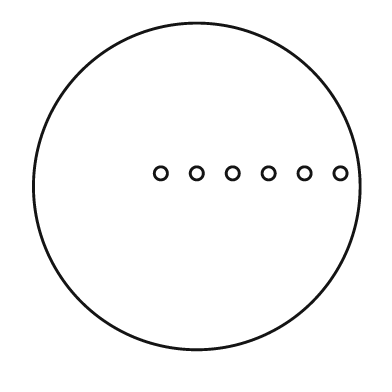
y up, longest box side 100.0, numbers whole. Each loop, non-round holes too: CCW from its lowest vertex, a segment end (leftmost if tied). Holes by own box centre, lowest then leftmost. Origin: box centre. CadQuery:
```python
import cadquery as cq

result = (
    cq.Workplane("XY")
    .moveTo(0.0, 0.0)
    .circle(50.0)
    .moveTo(-11.0, 4.0)
    .circle(2.0)
    .moveTo(0.0, 4.0)
    .circle(2.0)
    .moveTo(11.0, 4.0)
    .circle(2.0)
    .moveTo(22.0, 4.0)
    .circle(2.0)
    .moveTo(33.0, 4.0)
    .circle(2.0)
    .moveTo(44.0, 4.0)
    .circle(2.0)
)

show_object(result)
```